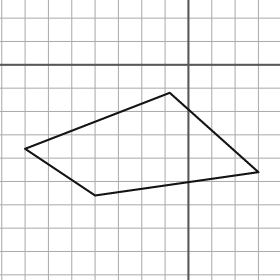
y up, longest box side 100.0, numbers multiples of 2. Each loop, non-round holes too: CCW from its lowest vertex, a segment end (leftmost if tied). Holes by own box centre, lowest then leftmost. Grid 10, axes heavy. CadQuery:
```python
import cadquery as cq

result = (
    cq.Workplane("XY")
    .moveTo(-40.0, -56.0)
    .lineTo(30.0, -46.0)
    .lineTo(-8.0, -12.0)
    .lineTo(-70.0, -36.0)
    .close()
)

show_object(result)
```